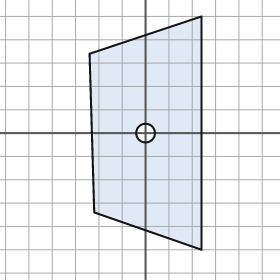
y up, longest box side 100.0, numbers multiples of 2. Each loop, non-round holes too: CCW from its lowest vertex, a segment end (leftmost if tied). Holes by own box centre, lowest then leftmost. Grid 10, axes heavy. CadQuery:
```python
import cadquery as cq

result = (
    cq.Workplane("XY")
    .moveTo(24.0, -50.0)
    .lineTo(24.0, 50.0)
    .lineTo(-24.0, 34.0)
    .lineTo(-22.0, -34.0)
    .close()
    .moveTo(0.0, 0.0)
    .circle(4.0)
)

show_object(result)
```